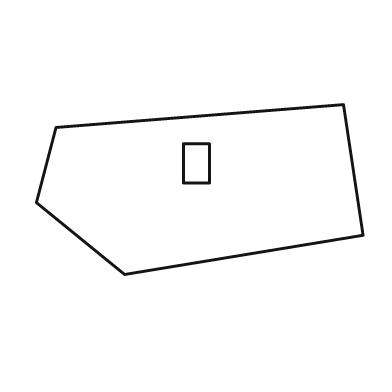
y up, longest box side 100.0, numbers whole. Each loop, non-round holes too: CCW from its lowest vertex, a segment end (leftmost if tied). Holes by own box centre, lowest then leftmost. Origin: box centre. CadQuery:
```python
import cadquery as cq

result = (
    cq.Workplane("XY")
    .moveTo(-23.0, -26.0)
    .lineTo(50.0, -14.0)
    .lineTo(44.0, 26.0)
    .lineTo(-44.0, 19.0)
    .lineTo(-50.0, -4.0)
    .close()
    .moveTo(-5.0, 2.0)
    .lineTo(3.0, 2.0)
    .lineTo(3.0, 14.0)
    .lineTo(-5.0, 14.0)
    .close()
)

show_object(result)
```